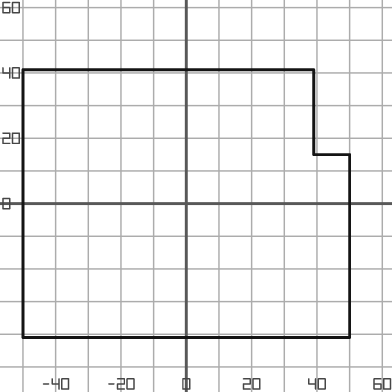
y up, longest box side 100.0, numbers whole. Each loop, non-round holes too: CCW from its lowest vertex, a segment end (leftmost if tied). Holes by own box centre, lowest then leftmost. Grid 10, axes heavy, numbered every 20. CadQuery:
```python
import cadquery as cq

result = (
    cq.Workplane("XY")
    .moveTo(-50.0, -41.0)
    .lineTo(50.0, -41.0)
    .lineTo(50.0, 15.0)
    .lineTo(39.0, 15.0)
    .lineTo(39.0, 41.0)
    .lineTo(-50.0, 41.0)
    .close()
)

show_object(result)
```